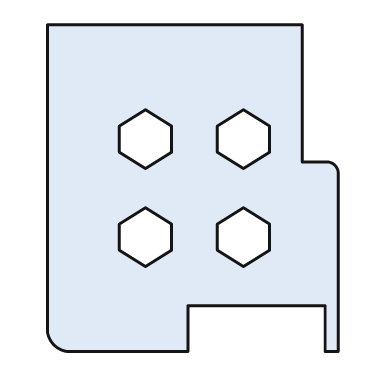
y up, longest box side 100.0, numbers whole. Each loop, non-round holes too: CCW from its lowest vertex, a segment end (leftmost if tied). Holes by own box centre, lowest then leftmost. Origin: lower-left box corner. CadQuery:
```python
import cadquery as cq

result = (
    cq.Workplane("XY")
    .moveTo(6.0, 0.0)
    .lineTo(43.0, 0.0)
    .lineTo(43.0, 14.0)
    .lineTo(85.0, 14.0)
    .lineTo(85.0, 0.0)
    .lineTo(89.0, 0.0)
    .lineTo(89.0, 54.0)
    .threePointArc((88.0, 57.0), (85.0, 58.0))
    .lineTo(78.0, 58.0)
    .lineTo(78.0, 100.0)
    .lineTo(0.0, 100.0)
    .lineTo(0.0, 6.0)
    .threePointArc((2.0, 2.0), (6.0, 0.0))
    .close()
    .moveTo(30.0, 26.0)
    .lineTo(38.0, 31.0)
    .lineTo(38.0, 39.0)
    .lineTo(30.0, 44.0)
    .lineTo(22.0, 39.0)
    .lineTo(22.0, 31.0)
    .close()
    .moveTo(60.0, 26.0)
    .lineTo(68.0, 31.0)
    .lineTo(68.0, 39.0)
    .lineTo(60.0, 44.0)
    .lineTo(52.0, 39.0)
    .lineTo(52.0, 31.0)
    .close()
    .moveTo(30.0, 56.0)
    .lineTo(38.0, 61.0)
    .lineTo(38.0, 69.0)
    .lineTo(30.0, 74.0)
    .lineTo(22.0, 69.0)
    .lineTo(22.0, 61.0)
    .close()
    .moveTo(60.0, 56.0)
    .lineTo(68.0, 61.0)
    .lineTo(68.0, 69.0)
    .lineTo(60.0, 74.0)
    .lineTo(52.0, 69.0)
    .lineTo(52.0, 61.0)
    .close()
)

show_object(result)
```